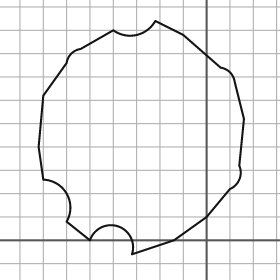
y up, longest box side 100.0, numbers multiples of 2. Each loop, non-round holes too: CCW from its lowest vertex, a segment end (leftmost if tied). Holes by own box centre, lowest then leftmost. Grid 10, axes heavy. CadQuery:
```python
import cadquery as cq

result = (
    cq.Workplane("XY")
    .moveTo(-32.0, -6.0)
    .lineTo(-14.0, 0.0)
    .lineTo(0.0, 10.0)
    .lineTo(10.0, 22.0)
    .threePointArc((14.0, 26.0), (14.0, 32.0))
    .lineTo(16.0, 52.0)
    .lineTo(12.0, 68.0)
    .threePointArc((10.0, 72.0), (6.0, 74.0))
    .lineTo(-10.0, 88.0)
    .lineTo(-22.0, 94.0)
    .threePointArc((-30.0, 88.0), (-40.0, 90.0))
    .lineTo(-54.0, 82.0)
    .threePointArc((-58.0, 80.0), (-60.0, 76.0))
    .lineTo(-70.0, 62.0)
    .lineTo(-72.0, 40.0)
    .lineTo(-70.0, 26.0)
    .threePointArc((-60.0, 20.0), (-60.0, 8.0))
    .lineTo(-50.0, 0.0)
    .threePointArc((-38.0, 6.0), (-32.0, -6.0))
    .close()
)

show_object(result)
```